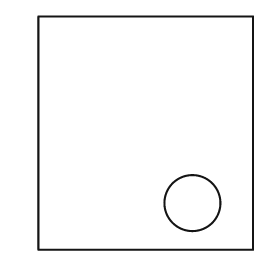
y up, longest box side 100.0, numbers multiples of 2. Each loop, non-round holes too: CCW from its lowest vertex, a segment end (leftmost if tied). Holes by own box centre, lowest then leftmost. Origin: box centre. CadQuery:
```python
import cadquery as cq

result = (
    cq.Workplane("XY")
    .moveTo(-46.0, -50.0)
    .lineTo(46.0, -50.0)
    .lineTo(46.0, 50.0)
    .lineTo(-46.0, 50.0)
    .close()
    .moveTo(20.0, -30.0)
    .circle(12.0)
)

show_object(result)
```